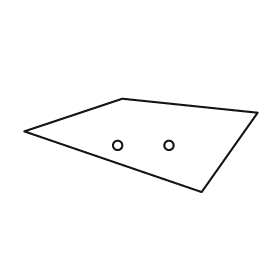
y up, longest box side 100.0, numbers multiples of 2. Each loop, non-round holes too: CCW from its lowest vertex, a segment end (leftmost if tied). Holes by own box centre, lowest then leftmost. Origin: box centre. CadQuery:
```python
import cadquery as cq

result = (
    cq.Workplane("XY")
    .moveTo(26.0, -20.0)
    .lineTo(50.0, 14.0)
    .lineTo(-8.0, 20.0)
    .lineTo(-50.0, 6.0)
    .close()
    .moveTo(-10.0, 0.0)
    .circle(2.0)
    .moveTo(12.0, 0.0)
    .circle(2.0)
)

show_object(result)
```